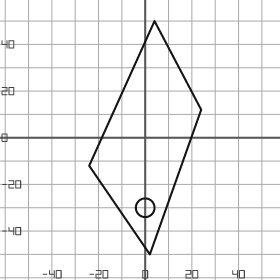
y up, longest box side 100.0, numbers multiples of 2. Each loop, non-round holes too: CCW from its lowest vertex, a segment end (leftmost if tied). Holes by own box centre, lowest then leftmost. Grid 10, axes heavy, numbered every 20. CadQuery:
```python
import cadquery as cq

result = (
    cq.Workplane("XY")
    .moveTo(2.0, -50.0)
    .lineTo(24.0, 12.0)
    .lineTo(4.0, 50.0)
    .lineTo(-24.0, -12.0)
    .close()
    .moveTo(0.0, -30.0)
    .circle(4.0)
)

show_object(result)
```